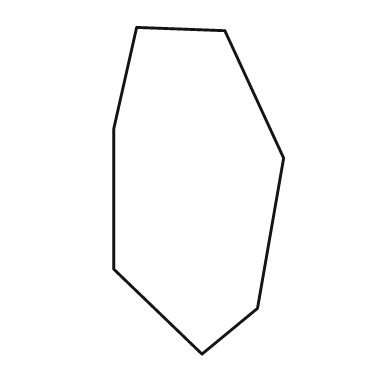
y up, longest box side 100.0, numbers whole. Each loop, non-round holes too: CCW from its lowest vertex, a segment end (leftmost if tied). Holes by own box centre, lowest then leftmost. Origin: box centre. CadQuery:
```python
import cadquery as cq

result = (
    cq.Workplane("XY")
    .moveTo(1.0, -50.0)
    .lineTo(18.0, -36.0)
    .lineTo(26.0, 10.0)
    .lineTo(8.0, 49.0)
    .lineTo(-19.0, 50.0)
    .lineTo(-26.0, 19.0)
    .lineTo(-26.0, -24.0)
    .close()
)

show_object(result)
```